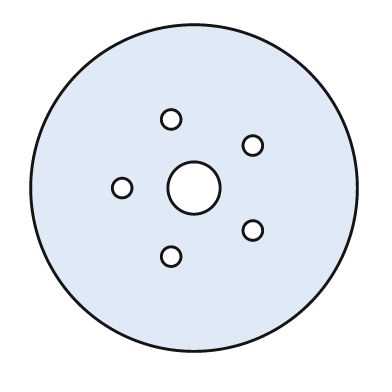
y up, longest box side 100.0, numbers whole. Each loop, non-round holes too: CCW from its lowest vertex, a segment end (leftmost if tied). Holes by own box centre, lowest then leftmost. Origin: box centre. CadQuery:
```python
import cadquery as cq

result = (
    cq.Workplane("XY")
    .moveTo(0.0, 0.0)
    .circle(50.0)
    .moveTo(-7.0, -21.0)
    .circle(3.0)
    .moveTo(18.0, -13.0)
    .circle(3.0)
    .moveTo(-22.0, 0.0)
    .circle(3.0)
    .moveTo(0.0, 0.0)
    .circle(8.0)
    .moveTo(18.0, 13.0)
    .circle(3.0)
    .moveTo(-7.0, 21.0)
    .circle(3.0)
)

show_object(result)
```